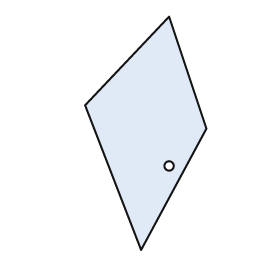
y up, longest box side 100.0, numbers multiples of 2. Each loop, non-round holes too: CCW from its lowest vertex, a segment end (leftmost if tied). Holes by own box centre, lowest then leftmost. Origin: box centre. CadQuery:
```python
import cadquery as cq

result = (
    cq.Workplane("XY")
    .moveTo(-2.0, -50.0)
    .lineTo(26.0, 2.0)
    .lineTo(10.0, 50.0)
    .lineTo(-26.0, 12.0)
    .close()
    .moveTo(10.0, -14.0)
    .circle(2.0)
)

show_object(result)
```